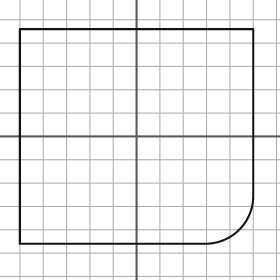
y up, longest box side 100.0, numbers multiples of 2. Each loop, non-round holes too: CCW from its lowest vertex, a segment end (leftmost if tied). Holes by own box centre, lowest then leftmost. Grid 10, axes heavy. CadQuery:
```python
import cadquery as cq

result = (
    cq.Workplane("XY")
    .moveTo(-50.0, -46.0)
    .lineTo(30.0, -46.0)
    .threePointArc((44.0, -40.0), (50.0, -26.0))
    .lineTo(50.0, 46.0)
    .lineTo(-50.0, 46.0)
    .close()
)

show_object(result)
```